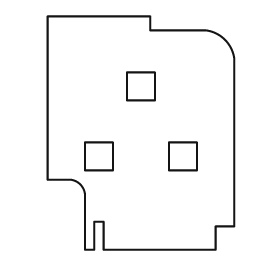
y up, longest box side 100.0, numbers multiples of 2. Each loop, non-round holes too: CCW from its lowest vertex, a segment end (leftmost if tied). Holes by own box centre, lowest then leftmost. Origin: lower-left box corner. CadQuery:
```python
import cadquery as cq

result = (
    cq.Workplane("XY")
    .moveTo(16.0, 0.0)
    .lineTo(20.0, 0.0)
    .lineTo(20.0, 12.0)
    .lineTo(24.0, 12.0)
    .lineTo(24.0, 0.0)
    .lineTo(72.0, 0.0)
    .lineTo(72.0, 10.0)
    .lineTo(80.0, 10.0)
    .lineTo(80.0, 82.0)
    .threePointArc((76.0, 90.0), (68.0, 94.0))
    .lineTo(44.0, 94.0)
    .lineTo(44.0, 100.0)
    .lineTo(0.0, 100.0)
    .lineTo(0.0, 30.0)
    .lineTo(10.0, 30.0)
    .threePointArc((14.0, 28.0), (16.0, 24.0))
    .close()
    .moveTo(16.0, 34.0)
    .lineTo(28.0, 34.0)
    .lineTo(28.0, 46.0)
    .lineTo(16.0, 46.0)
    .close()
    .moveTo(52.0, 34.0)
    .lineTo(64.0, 34.0)
    .lineTo(64.0, 46.0)
    .lineTo(52.0, 46.0)
    .close()
    .moveTo(34.0, 64.0)
    .lineTo(46.0, 64.0)
    .lineTo(46.0, 76.0)
    .lineTo(34.0, 76.0)
    .close()
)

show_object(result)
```